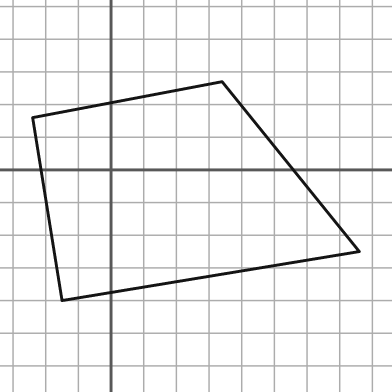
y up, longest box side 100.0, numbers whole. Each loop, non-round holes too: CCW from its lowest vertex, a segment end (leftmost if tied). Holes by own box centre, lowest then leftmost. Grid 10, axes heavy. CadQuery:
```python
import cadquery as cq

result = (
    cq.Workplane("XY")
    .moveTo(-15.0, -40.0)
    .lineTo(76.0, -25.0)
    .lineTo(34.0, 27.0)
    .lineTo(-24.0, 16.0)
    .close()
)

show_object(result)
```